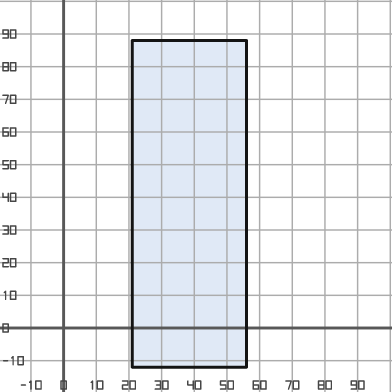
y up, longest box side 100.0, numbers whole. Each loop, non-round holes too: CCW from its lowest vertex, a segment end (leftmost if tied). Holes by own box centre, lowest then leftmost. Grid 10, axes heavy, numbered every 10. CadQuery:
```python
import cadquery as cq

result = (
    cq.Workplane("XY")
    .moveTo(21.0, -12.0)
    .lineTo(56.0, -12.0)
    .lineTo(56.0, 88.0)
    .lineTo(21.0, 88.0)
    .close()
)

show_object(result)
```